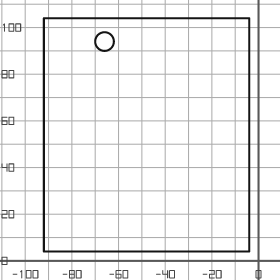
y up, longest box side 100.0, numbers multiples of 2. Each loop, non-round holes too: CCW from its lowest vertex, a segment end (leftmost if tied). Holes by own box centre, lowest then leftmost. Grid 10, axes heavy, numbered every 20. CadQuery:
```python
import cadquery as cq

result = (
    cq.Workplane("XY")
    .moveTo(-92.0, 4.0)
    .lineTo(-4.0, 4.0)
    .lineTo(-4.0, 104.0)
    .lineTo(-92.0, 104.0)
    .close()
    .moveTo(-66.0, 94.0)
    .circle(4.0)
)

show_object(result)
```